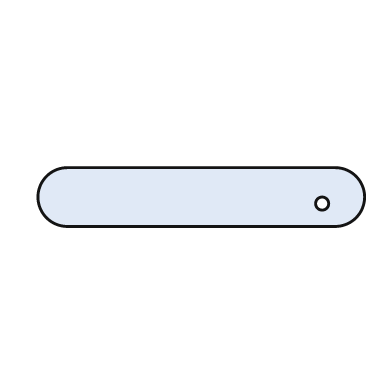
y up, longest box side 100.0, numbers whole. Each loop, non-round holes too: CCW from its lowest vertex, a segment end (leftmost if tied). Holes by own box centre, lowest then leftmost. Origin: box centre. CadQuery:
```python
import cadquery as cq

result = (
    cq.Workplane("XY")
    .moveTo(-41.0, -9.0)
    .lineTo(41.0, -9.0)
    .threePointArc((50.0, 0.0), (41.0, 9.0))
    .lineTo(-41.0, 9.0)
    .threePointArc((-50.0, 0.0), (-41.0, -9.0))
    .close()
    .moveTo(37.0, -2.0)
    .circle(2.0)
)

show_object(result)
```